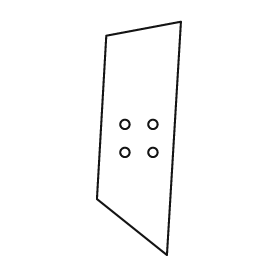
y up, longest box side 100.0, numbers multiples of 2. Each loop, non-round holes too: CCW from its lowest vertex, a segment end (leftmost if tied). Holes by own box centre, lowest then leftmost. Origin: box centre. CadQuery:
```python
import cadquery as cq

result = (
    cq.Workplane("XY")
    .moveTo(12.0, -50.0)
    .lineTo(18.0, 50.0)
    .lineTo(-14.0, 44.0)
    .lineTo(-18.0, -26.0)
    .close()
    .moveTo(-6.0, -6.0)
    .circle(2.0)
    .moveTo(6.0, -6.0)
    .circle(2.0)
    .moveTo(-6.0, 6.0)
    .circle(2.0)
    .moveTo(6.0, 6.0)
    .circle(2.0)
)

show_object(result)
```